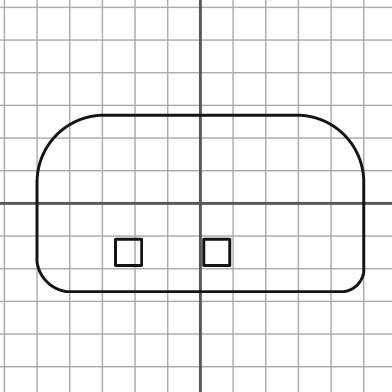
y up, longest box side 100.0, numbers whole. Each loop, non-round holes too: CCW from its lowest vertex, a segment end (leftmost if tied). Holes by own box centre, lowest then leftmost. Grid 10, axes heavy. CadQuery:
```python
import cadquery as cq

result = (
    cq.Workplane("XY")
    .moveTo(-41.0, -27.0)
    .lineTo(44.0, -27.0)
    .threePointArc((48.0, -25.0), (50.0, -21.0))
    .lineTo(50.0, 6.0)
    .threePointArc((44.0, 21.0), (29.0, 27.0))
    .lineTo(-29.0, 27.0)
    .threePointArc((-44.0, 21.0), (-50.0, 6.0))
    .lineTo(-50.0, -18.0)
    .threePointArc((-47.0, -24.0), (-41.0, -27.0))
    .close()
    .moveTo(-26.0, -19.0)
    .lineTo(-18.0, -19.0)
    .lineTo(-18.0, -11.0)
    .lineTo(-26.0, -11.0)
    .close()
    .moveTo(1.0, -19.0)
    .lineTo(9.0, -19.0)
    .lineTo(9.0, -11.0)
    .lineTo(1.0, -11.0)
    .close()
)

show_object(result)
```